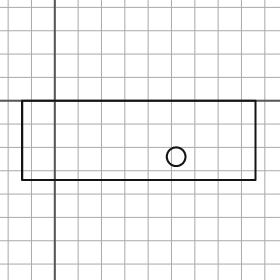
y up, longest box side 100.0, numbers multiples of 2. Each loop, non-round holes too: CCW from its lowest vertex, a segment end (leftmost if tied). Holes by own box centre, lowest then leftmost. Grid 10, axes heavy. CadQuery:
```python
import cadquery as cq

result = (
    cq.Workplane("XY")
    .moveTo(-14.0, -34.0)
    .lineTo(86.0, -34.0)
    .lineTo(86.0, 0.0)
    .lineTo(-14.0, 0.0)
    .close()
    .moveTo(52.0, -24.0)
    .circle(4.0)
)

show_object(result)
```